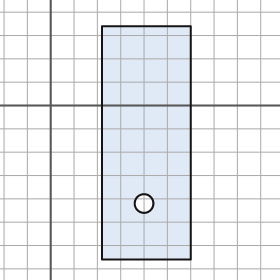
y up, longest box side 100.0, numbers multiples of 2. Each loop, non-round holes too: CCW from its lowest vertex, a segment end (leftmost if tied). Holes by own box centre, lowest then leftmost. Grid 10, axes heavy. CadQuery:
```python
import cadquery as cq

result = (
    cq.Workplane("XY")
    .moveTo(22.0, -66.0)
    .lineTo(60.0, -66.0)
    .lineTo(60.0, 34.0)
    .lineTo(22.0, 34.0)
    .close()
    .moveTo(40.0, -42.0)
    .circle(4.0)
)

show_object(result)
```